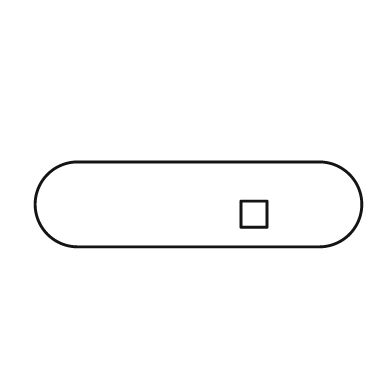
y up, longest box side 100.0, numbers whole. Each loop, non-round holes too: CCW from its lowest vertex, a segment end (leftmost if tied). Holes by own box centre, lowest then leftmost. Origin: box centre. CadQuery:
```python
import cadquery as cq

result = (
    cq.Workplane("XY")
    .moveTo(-37.0, -13.0)
    .lineTo(37.0, -13.0)
    .threePointArc((50.0, 0.0), (37.0, 13.0))
    .lineTo(-37.0, 13.0)
    .threePointArc((-50.0, 0.0), (-37.0, -13.0))
    .close()
    .moveTo(13.0, -7.0)
    .lineTo(21.0, -7.0)
    .lineTo(21.0, 1.0)
    .lineTo(13.0, 1.0)
    .close()
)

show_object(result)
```